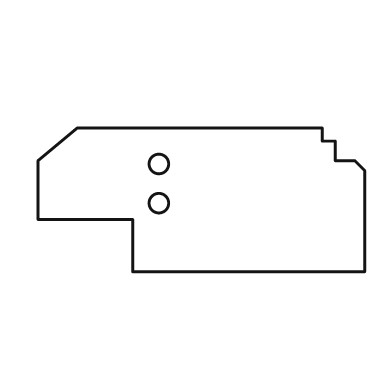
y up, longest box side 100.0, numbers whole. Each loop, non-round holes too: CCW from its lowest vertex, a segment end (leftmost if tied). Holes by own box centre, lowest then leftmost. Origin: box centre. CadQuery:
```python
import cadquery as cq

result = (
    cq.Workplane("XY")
    .moveTo(-21.0, -22.0)
    .lineTo(50.0, -22.0)
    .lineTo(50.0, 9.0)
    .lineTo(47.0, 12.0)
    .lineTo(41.0, 12.0)
    .lineTo(41.0, 18.0)
    .lineTo(37.0, 18.0)
    .lineTo(37.0, 22.0)
    .lineTo(-38.0, 22.0)
    .lineTo(-50.0, 12.0)
    .lineTo(-50.0, -6.0)
    .lineTo(-21.0, -6.0)
    .close()
    .moveTo(-13.0, -1.0)
    .circle(3.0)
    .moveTo(-13.0, 11.0)
    .circle(3.0)
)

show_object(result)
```